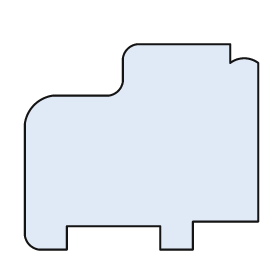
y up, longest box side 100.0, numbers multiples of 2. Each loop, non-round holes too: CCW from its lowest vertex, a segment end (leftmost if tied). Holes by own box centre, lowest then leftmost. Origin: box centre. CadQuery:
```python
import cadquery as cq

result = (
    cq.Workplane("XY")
    .moveTo(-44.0, -44.0)
    .lineTo(-32.0, -44.0)
    .lineTo(-32.0, -34.0)
    .lineTo(8.0, -34.0)
    .lineTo(8.0, -44.0)
    .lineTo(22.0, -44.0)
    .lineTo(22.0, -32.0)
    .lineTo(50.0, -32.0)
    .lineTo(50.0, 36.0)
    .threePointArc((44.0, 38.0), (38.0, 36.0))
    .lineTo(38.0, 44.0)
    .lineTo(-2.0, 44.0)
    .threePointArc((-6.0, 42.0), (-8.0, 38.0))
    .lineTo(-8.0, 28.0)
    .threePointArc((-10.0, 24.0), (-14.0, 22.0))
    .lineTo(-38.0, 22.0)
    .threePointArc((-46.0, 18.0), (-50.0, 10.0))
    .lineTo(-50.0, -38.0)
    .threePointArc((-48.0, -42.0), (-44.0, -44.0))
    .close()
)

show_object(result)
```